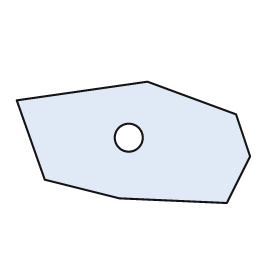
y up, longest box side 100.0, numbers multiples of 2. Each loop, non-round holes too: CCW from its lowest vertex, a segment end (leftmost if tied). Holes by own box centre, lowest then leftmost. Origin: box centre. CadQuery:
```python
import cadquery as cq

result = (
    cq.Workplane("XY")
    .moveTo(40.0, -26.0)
    .lineTo(50.0, -6.0)
    .lineTo(44.0, 12.0)
    .lineTo(6.0, 26.0)
    .lineTo(-50.0, 18.0)
    .lineTo(-38.0, -16.0)
    .lineTo(-6.0, -24.0)
    .close()
    .moveTo(-2.0, 2.0)
    .circle(6.0)
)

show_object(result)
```